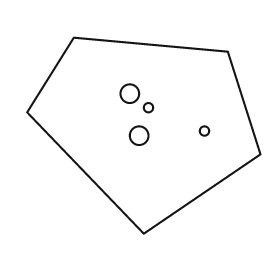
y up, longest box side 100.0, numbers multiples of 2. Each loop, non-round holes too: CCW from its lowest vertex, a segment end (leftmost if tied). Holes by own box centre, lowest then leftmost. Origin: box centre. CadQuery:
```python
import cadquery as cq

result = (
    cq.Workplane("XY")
    .moveTo(0.0, -42.0)
    .lineTo(50.0, -8.0)
    .lineTo(36.0, 36.0)
    .lineTo(-30.0, 42.0)
    .lineTo(-50.0, 10.0)
    .close()
    .moveTo(-2.0, 0.0)
    .circle(4.0)
    .moveTo(26.0, 2.0)
    .circle(2.0)
    .moveTo(2.0, 12.0)
    .circle(2.0)
    .moveTo(-6.0, 18.0)
    .circle(4.0)
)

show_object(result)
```